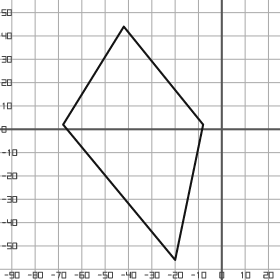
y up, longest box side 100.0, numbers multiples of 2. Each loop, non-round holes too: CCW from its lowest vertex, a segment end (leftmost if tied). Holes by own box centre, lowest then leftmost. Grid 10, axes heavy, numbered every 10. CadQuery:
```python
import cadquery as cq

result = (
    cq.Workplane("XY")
    .moveTo(-20.0, -56.0)
    .lineTo(-8.0, 2.0)
    .lineTo(-42.0, 44.0)
    .lineTo(-68.0, 2.0)
    .close()
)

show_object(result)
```